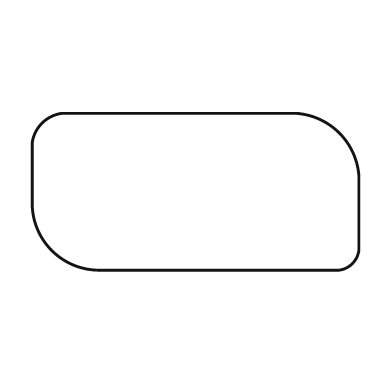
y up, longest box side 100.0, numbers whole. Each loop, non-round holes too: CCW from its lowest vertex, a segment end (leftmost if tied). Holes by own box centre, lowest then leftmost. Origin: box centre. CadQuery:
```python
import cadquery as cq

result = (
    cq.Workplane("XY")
    .moveTo(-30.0, -24.0)
    .lineTo(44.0, -24.0)
    .threePointArc((48.0, -22.0), (50.0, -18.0))
    .lineTo(50.0, 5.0)
    .threePointArc((44.0, 18.0), (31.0, 24.0))
    .lineTo(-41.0, 24.0)
    .threePointArc((-47.0, 21.0), (-50.0, 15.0))
    .lineTo(-50.0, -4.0)
    .threePointArc((-44.0, -18.0), (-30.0, -24.0))
    .close()
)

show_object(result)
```